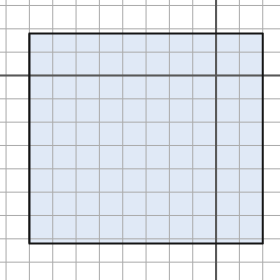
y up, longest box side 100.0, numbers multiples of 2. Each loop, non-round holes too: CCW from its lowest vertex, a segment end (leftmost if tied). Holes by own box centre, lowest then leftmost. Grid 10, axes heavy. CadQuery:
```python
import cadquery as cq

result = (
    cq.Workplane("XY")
    .moveTo(-80.0, -72.0)
    .lineTo(20.0, -72.0)
    .lineTo(20.0, 18.0)
    .lineTo(-80.0, 18.0)
    .close()
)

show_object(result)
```